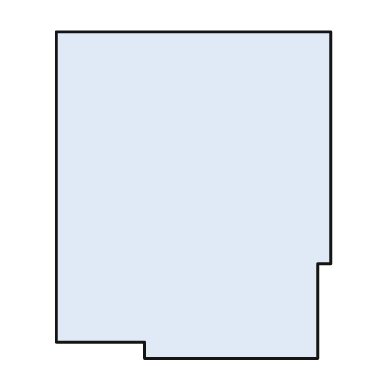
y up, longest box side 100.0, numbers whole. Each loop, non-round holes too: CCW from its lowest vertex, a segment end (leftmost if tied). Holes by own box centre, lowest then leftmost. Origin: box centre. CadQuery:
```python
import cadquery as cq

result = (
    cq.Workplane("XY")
    .moveTo(-15.0, -50.0)
    .lineTo(38.0, -50.0)
    .lineTo(38.0, -21.0)
    .lineTo(42.0, -21.0)
    .lineTo(42.0, 50.0)
    .lineTo(-42.0, 50.0)
    .lineTo(-42.0, -45.0)
    .lineTo(-15.0, -45.0)
    .close()
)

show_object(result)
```